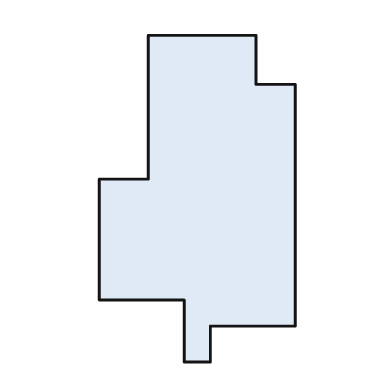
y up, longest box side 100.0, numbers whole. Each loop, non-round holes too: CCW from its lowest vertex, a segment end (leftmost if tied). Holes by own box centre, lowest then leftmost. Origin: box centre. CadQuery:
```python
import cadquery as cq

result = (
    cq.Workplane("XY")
    .moveTo(-4.0, -50.0)
    .lineTo(4.0, -50.0)
    .lineTo(4.0, -39.0)
    .lineTo(30.0, -39.0)
    .lineTo(30.0, 35.0)
    .lineTo(18.0, 35.0)
    .lineTo(18.0, 50.0)
    .lineTo(-15.0, 50.0)
    .lineTo(-15.0, 6.0)
    .lineTo(-30.0, 6.0)
    .lineTo(-30.0, -31.0)
    .lineTo(-4.0, -31.0)
    .close()
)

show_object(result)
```